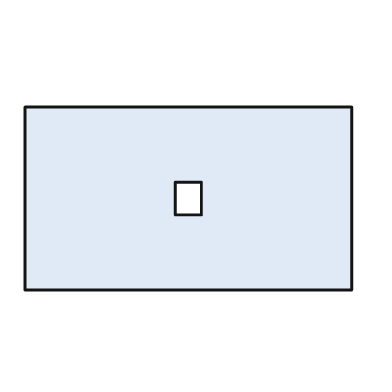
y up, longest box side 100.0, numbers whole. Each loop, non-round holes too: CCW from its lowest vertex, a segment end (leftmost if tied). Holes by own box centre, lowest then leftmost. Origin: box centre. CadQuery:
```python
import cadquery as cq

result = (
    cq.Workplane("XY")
    .moveTo(-50.0, -28.0)
    .lineTo(50.0, -28.0)
    .lineTo(50.0, 28.0)
    .lineTo(-50.0, 28.0)
    .close()
    .moveTo(-4.0, -5.0)
    .lineTo(4.0, -5.0)
    .lineTo(4.0, 5.0)
    .lineTo(-4.0, 5.0)
    .close()
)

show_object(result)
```